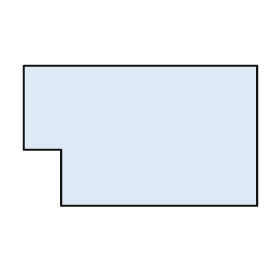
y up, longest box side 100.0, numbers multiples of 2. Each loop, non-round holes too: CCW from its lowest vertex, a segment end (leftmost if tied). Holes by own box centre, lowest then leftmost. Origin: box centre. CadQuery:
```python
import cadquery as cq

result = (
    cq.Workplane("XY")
    .moveTo(-34.0, -30.0)
    .lineTo(50.0, -30.0)
    .lineTo(50.0, 30.0)
    .lineTo(-50.0, 30.0)
    .lineTo(-50.0, -6.0)
    .lineTo(-34.0, -6.0)
    .close()
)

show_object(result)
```